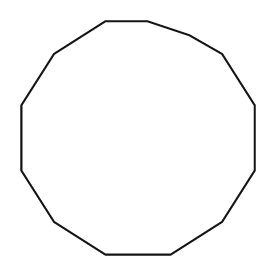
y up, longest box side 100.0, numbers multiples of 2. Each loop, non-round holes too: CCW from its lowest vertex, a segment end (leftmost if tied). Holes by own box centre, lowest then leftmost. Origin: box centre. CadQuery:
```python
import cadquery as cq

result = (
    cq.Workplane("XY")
    .moveTo(-14.0, -50.0)
    .lineTo(14.0, -50.0)
    .lineTo(36.0, -36.0)
    .lineTo(50.0, -14.0)
    .lineTo(50.0, 14.0)
    .lineTo(36.0, 36.0)
    .lineTo(22.0, 44.0)
    .lineTo(4.0, 50.0)
    .lineTo(-14.0, 50.0)
    .lineTo(-36.0, 36.0)
    .lineTo(-50.0, 14.0)
    .lineTo(-50.0, -14.0)
    .lineTo(-36.0, -36.0)
    .close()
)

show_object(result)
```